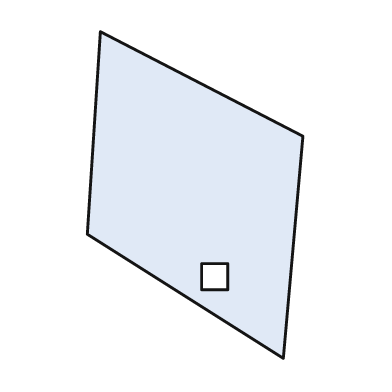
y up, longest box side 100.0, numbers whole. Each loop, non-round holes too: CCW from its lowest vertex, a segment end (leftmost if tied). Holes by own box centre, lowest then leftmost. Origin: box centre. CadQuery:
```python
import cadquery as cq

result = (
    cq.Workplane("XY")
    .moveTo(27.0, -50.0)
    .lineTo(33.0, 18.0)
    .lineTo(-29.0, 50.0)
    .lineTo(-33.0, -12.0)
    .close()
    .moveTo(2.0, -29.0)
    .lineTo(10.0, -29.0)
    .lineTo(10.0, -21.0)
    .lineTo(2.0, -21.0)
    .close()
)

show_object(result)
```